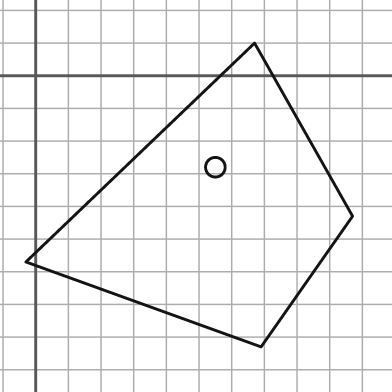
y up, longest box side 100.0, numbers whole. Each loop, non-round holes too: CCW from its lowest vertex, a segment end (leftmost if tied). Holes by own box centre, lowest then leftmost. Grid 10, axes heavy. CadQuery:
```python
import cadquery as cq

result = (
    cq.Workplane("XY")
    .moveTo(69.0, -83.0)
    .lineTo(97.0, -43.0)
    .lineTo(67.0, 10.0)
    .lineTo(-3.0, -57.0)
    .close()
    .moveTo(55.0, -28.0)
    .circle(3.0)
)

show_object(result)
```